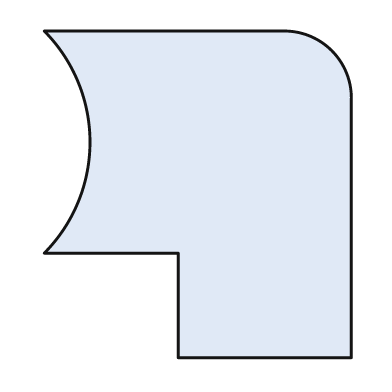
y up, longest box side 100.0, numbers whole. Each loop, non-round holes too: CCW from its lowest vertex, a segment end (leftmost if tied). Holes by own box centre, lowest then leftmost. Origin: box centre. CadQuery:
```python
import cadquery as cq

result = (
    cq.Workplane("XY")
    .moveTo(-6.0, -50.0)
    .lineTo(47.0, -50.0)
    .lineTo(47.0, 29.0)
    .threePointArc((41.0, 44.0), (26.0, 50.0))
    .lineTo(-47.0, 50.0)
    .threePointArc((-33.0, 16.0), (-47.0, -18.0))
    .lineTo(-6.0, -18.0)
    .close()
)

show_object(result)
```